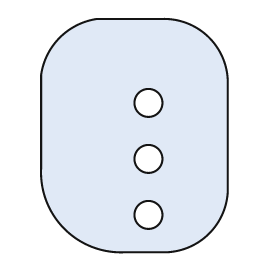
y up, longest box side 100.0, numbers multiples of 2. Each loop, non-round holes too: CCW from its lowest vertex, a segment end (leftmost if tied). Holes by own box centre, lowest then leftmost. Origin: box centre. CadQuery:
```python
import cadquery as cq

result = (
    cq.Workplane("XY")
    .moveTo(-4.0, -50.0)
    .lineTo(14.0, -50.0)
    .threePointArc((32.0, -42.0), (40.0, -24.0))
    .lineTo(40.0, 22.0)
    .threePointArc((32.0, 42.0), (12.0, 50.0))
    .lineTo(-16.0, 50.0)
    .threePointArc((-32.0, 42.0), (-40.0, 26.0))
    .lineTo(-40.0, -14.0)
    .threePointArc((-30.0, -40.0), (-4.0, -50.0))
    .close()
    .moveTo(6.0, -34.0)
    .circle(6.0)
    .moveTo(6.0, -10.0)
    .circle(6.0)
    .moveTo(6.0, 14.0)
    .circle(6.0)
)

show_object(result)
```